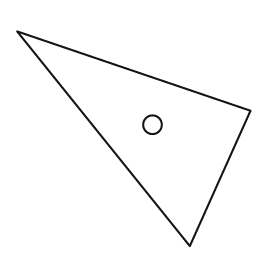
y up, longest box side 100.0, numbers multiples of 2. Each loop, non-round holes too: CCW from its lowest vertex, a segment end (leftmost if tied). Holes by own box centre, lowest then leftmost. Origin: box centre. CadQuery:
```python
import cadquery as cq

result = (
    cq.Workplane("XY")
    .moveTo(24.0, -46.0)
    .lineTo(50.0, 12.0)
    .lineTo(-50.0, 46.0)
    .close()
    .moveTo(8.0, 6.0)
    .circle(4.0)
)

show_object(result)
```